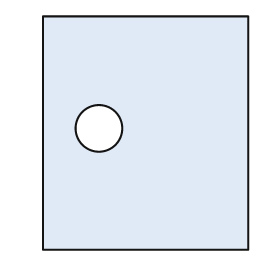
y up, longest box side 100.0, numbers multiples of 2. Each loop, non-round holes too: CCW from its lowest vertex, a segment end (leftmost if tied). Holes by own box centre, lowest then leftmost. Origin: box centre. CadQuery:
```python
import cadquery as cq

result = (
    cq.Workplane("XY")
    .moveTo(-44.0, -50.0)
    .lineTo(44.0, -50.0)
    .lineTo(44.0, 50.0)
    .lineTo(-44.0, 50.0)
    .close()
    .moveTo(-20.0, 2.0)
    .circle(10.0)
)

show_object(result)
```